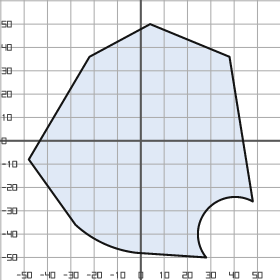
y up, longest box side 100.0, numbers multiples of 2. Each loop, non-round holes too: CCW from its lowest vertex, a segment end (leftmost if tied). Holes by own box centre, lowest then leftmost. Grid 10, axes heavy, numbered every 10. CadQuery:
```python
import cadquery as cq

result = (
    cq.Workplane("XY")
    .moveTo(28.0, -50.0)
    .threePointArc((28.0, -30.0), (48.0, -26.0))
    .lineTo(38.0, 36.0)
    .lineTo(4.0, 50.0)
    .lineTo(-22.0, 36.0)
    .lineTo(-48.0, -8.0)
    .lineTo(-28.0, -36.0)
    .threePointArc((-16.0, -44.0), (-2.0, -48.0))
    .close()
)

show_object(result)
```